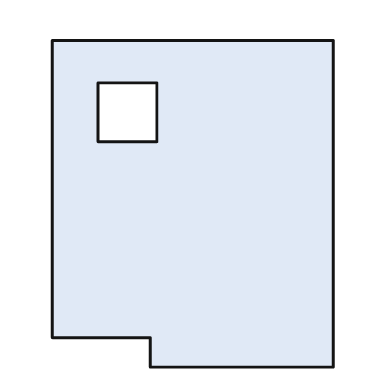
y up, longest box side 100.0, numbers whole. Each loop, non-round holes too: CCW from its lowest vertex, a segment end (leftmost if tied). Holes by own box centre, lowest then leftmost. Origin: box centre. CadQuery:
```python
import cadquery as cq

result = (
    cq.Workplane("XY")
    .moveTo(-13.0, -50.0)
    .lineTo(43.0, -50.0)
    .lineTo(43.0, 50.0)
    .lineTo(-43.0, 50.0)
    .lineTo(-43.0, -41.0)
    .lineTo(-13.0, -41.0)
    .close()
    .moveTo(-29.0, 19.0)
    .lineTo(-11.0, 19.0)
    .lineTo(-11.0, 37.0)
    .lineTo(-29.0, 37.0)
    .close()
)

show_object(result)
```